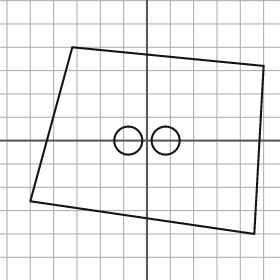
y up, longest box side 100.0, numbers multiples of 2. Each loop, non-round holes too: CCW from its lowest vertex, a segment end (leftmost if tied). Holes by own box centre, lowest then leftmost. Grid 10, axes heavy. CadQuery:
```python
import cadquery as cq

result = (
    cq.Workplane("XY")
    .moveTo(46.0, -40.0)
    .lineTo(50.0, 32.0)
    .lineTo(-32.0, 40.0)
    .lineTo(-50.0, -26.0)
    .close()
    .moveTo(-8.0, 0.0)
    .circle(6.0)
    .moveTo(8.0, 0.0)
    .circle(6.0)
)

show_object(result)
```